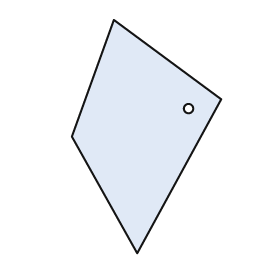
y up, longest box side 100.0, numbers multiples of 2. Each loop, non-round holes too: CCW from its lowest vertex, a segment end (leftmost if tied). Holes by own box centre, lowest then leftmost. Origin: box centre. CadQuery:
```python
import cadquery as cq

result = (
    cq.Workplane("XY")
    .moveTo(-4.0, -50.0)
    .lineTo(32.0, 16.0)
    .lineTo(-14.0, 50.0)
    .lineTo(-32.0, 0.0)
    .close()
    .moveTo(18.0, 12.0)
    .circle(2.0)
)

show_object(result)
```